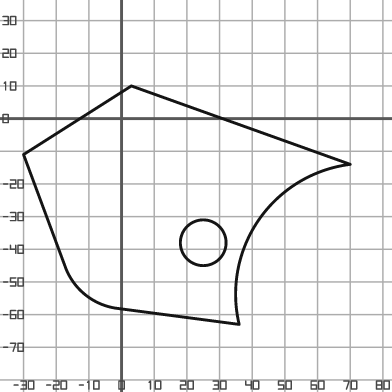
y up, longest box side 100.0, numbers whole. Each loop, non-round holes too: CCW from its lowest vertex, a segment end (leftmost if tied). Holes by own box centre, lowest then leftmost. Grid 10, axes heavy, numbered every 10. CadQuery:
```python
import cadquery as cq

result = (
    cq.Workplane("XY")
    .moveTo(36.0, -63.0)
    .threePointArc((42.0, -31.0), (70.0, -14.0))
    .lineTo(3.0, 10.0)
    .lineTo(-30.0, -11.0)
    .lineTo(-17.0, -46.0)
    .threePointArc((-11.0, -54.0), (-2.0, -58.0))
    .close()
    .moveTo(25.0, -38.0)
    .circle(7.0)
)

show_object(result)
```